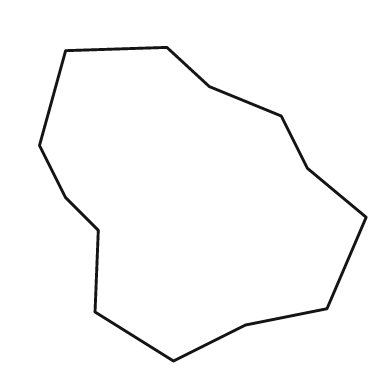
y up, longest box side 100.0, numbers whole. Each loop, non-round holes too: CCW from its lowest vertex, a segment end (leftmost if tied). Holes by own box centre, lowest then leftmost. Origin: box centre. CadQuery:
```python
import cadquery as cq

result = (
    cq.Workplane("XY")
    .moveTo(-9.0, -48.0)
    .lineTo(13.0, -37.0)
    .lineTo(38.0, -32.0)
    .lineTo(50.0, -4.0)
    .lineTo(32.0, 11.0)
    .lineTo(24.0, 27.0)
    .lineTo(2.0, 36.0)
    .lineTo(-11.0, 48.0)
    .lineTo(-42.0, 47.0)
    .lineTo(-50.0, 18.0)
    .lineTo(-42.0, 2.0)
    .lineTo(-32.0, -8.0)
    .lineTo(-33.0, -33.0)
    .close()
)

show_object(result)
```